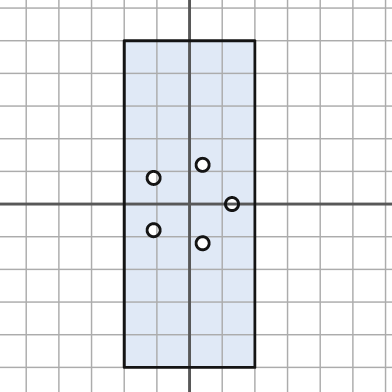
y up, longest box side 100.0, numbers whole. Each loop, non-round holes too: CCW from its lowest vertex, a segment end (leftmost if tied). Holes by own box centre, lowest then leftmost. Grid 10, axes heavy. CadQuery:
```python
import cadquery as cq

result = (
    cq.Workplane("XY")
    .moveTo(-20.0, -50.0)
    .lineTo(20.0, -50.0)
    .lineTo(20.0, 50.0)
    .lineTo(-20.0, 50.0)
    .close()
    .moveTo(4.0, -12.0)
    .circle(2.0)
    .moveTo(-11.0, -8.0)
    .circle(2.0)
    .moveTo(13.0, 0.0)
    .circle(2.0)
    .moveTo(-11.0, 8.0)
    .circle(2.0)
    .moveTo(4.0, 12.0)
    .circle(2.0)
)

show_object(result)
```